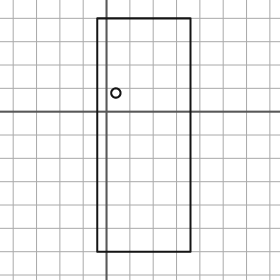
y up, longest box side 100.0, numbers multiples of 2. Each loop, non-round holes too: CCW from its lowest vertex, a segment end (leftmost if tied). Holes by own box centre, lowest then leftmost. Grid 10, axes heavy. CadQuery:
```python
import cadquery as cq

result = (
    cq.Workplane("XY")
    .moveTo(-4.0, -60.0)
    .lineTo(36.0, -60.0)
    .lineTo(36.0, 40.0)
    .lineTo(-4.0, 40.0)
    .close()
    .moveTo(4.0, 8.0)
    .circle(2.0)
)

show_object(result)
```